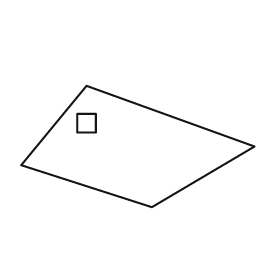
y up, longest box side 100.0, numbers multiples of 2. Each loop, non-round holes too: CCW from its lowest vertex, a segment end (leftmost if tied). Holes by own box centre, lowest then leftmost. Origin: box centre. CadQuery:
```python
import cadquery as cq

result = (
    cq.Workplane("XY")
    .moveTo(6.0, -26.0)
    .lineTo(50.0, 0.0)
    .lineTo(-22.0, 26.0)
    .lineTo(-50.0, -8.0)
    .close()
    .moveTo(-26.0, 6.0)
    .lineTo(-18.0, 6.0)
    .lineTo(-18.0, 14.0)
    .lineTo(-26.0, 14.0)
    .close()
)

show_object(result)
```